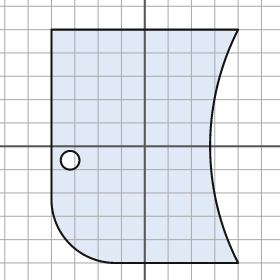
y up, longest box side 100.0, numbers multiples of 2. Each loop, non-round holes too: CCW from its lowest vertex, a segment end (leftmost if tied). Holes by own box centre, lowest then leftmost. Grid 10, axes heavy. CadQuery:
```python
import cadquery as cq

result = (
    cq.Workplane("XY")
    .moveTo(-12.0, -50.0)
    .lineTo(40.0, -50.0)
    .threePointArc((28.0, 0.0), (40.0, 50.0))
    .lineTo(-40.0, 50.0)
    .lineTo(-40.0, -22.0)
    .threePointArc((-32.0, -42.0), (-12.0, -50.0))
    .close()
    .moveTo(-32.0, -6.0)
    .circle(4.0)
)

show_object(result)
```